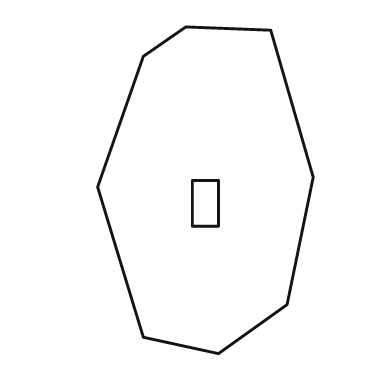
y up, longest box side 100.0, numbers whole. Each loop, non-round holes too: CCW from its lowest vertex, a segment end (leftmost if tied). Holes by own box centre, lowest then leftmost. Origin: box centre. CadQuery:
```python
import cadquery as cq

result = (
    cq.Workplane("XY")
    .moveTo(4.0, -50.0)
    .lineTo(25.0, -35.0)
    .lineTo(33.0, 4.0)
    .lineTo(20.0, 49.0)
    .lineTo(-6.0, 50.0)
    .lineTo(-19.0, 41.0)
    .lineTo(-33.0, 1.0)
    .lineTo(-19.0, -45.0)
    .close()
    .moveTo(-4.0, -11.0)
    .lineTo(4.0, -11.0)
    .lineTo(4.0, 3.0)
    .lineTo(-4.0, 3.0)
    .close()
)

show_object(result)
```